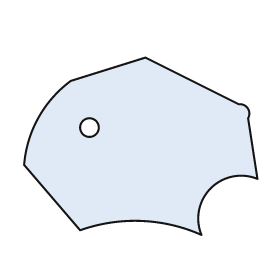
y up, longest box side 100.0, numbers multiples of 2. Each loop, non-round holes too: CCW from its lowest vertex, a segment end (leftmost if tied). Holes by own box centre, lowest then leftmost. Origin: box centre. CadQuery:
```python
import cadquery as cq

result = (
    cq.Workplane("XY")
    .moveTo(26.0, -38.0)
    .threePointArc((30.0, -18.0), (50.0, -14.0))
    .lineTo(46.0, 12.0)
    .threePointArc((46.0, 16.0), (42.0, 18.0))
    .lineTo(2.0, 38.0)
    .lineTo(-30.0, 28.0)
    .threePointArc((-44.0, 12.0), (-50.0, -8.0))
    .lineTo(-26.0, -36.0)
    .threePointArc((0.0, -32.0), (26.0, -38.0))
    .close()
    .moveTo(-22.0, 8.0)
    .circle(4.0)
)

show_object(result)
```